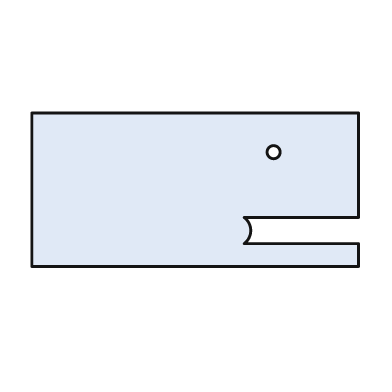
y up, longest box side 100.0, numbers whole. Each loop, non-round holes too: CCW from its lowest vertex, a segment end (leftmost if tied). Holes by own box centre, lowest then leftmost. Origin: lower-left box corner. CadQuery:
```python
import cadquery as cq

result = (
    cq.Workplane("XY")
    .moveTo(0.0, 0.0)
    .lineTo(100.0, 0.0)
    .lineTo(100.0, 7.0)
    .lineTo(65.0, 7.0)
    .threePointArc((67.0, 11.0), (65.0, 15.0))
    .lineTo(100.0, 15.0)
    .lineTo(100.0, 47.0)
    .lineTo(0.0, 47.0)
    .close()
    .moveTo(74.0, 35.0)
    .circle(2.0)
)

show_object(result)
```